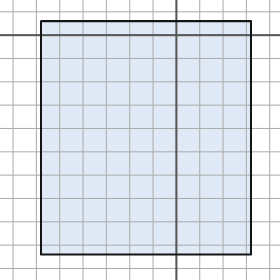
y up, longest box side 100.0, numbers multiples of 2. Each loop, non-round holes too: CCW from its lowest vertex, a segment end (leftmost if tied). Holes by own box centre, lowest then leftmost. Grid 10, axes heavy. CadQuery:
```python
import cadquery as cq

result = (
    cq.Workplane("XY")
    .moveTo(-58.0, -94.0)
    .lineTo(32.0, -94.0)
    .lineTo(32.0, 6.0)
    .lineTo(-58.0, 6.0)
    .close()
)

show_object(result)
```